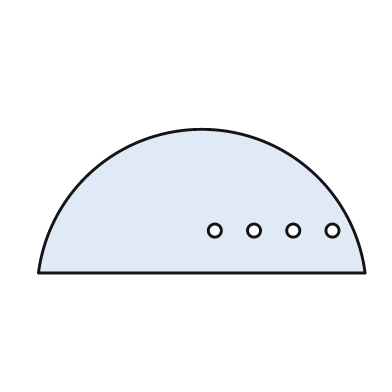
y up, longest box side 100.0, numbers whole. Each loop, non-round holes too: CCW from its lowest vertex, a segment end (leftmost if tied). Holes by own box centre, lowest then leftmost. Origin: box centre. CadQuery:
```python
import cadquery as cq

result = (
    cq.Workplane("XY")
    .moveTo(-50.0, -22.0)
    .lineTo(50.0, -22.0)
    .threePointArc((0.0, 22.0), (-50.0, -22.0))
    .close()
    .moveTo(4.0, -9.0)
    .circle(2.0)
    .moveTo(16.0, -9.0)
    .circle(2.0)
    .moveTo(28.0, -9.0)
    .circle(2.0)
    .moveTo(40.0, -9.0)
    .circle(2.0)
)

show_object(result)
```